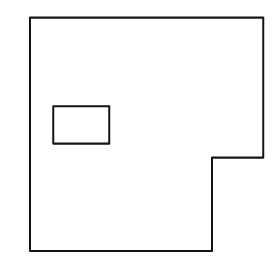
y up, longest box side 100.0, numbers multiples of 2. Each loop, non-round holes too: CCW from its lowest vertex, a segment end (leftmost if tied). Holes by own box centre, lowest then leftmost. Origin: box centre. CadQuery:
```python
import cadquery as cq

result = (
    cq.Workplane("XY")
    .moveTo(-50.0, -50.0)
    .lineTo(28.0, -50.0)
    .lineTo(28.0, -10.0)
    .lineTo(50.0, -10.0)
    .lineTo(50.0, 50.0)
    .lineTo(-50.0, 50.0)
    .close()
    .moveTo(-40.0, -4.0)
    .lineTo(-16.0, -4.0)
    .lineTo(-16.0, 12.0)
    .lineTo(-40.0, 12.0)
    .close()
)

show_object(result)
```